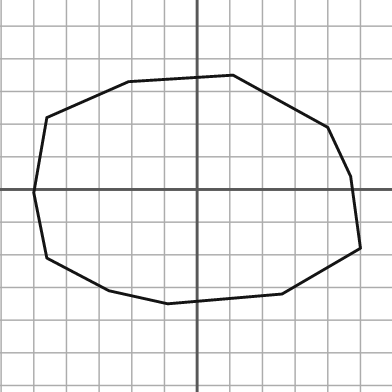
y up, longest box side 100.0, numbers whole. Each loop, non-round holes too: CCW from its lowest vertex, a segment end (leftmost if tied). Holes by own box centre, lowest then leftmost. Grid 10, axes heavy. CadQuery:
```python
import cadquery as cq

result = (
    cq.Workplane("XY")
    .moveTo(-9.0, -35.0)
    .lineTo(26.0, -32.0)
    .lineTo(50.0, -18.0)
    .lineTo(47.0, 4.0)
    .lineTo(40.0, 19.0)
    .lineTo(11.0, 35.0)
    .lineTo(-21.0, 33.0)
    .lineTo(-46.0, 22.0)
    .lineTo(-50.0, -1.0)
    .lineTo(-46.0, -21.0)
    .lineTo(-27.0, -31.0)
    .close()
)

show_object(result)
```